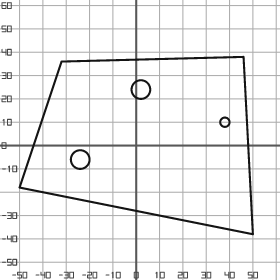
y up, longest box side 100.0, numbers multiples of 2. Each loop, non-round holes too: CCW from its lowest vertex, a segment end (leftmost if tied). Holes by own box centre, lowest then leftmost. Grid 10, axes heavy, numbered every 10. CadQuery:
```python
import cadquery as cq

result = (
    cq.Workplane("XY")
    .moveTo(50.0, -38.0)
    .lineTo(46.0, 38.0)
    .lineTo(-32.0, 36.0)
    .lineTo(-50.0, -18.0)
    .close()
    .moveTo(-24.0, -6.0)
    .circle(4.0)
    .moveTo(38.0, 10.0)
    .circle(2.0)
    .moveTo(2.0, 24.0)
    .circle(4.0)
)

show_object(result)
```